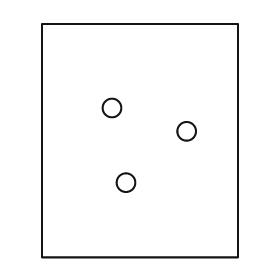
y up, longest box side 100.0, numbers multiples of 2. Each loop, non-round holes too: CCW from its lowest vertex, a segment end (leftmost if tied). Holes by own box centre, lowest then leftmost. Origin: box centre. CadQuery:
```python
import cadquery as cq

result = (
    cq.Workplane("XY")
    .moveTo(-42.0, -50.0)
    .lineTo(42.0, -50.0)
    .lineTo(42.0, 50.0)
    .lineTo(-42.0, 50.0)
    .close()
    .moveTo(-6.0, -18.0)
    .circle(4.0)
    .moveTo(20.0, 4.0)
    .circle(4.0)
    .moveTo(-12.0, 14.0)
    .circle(4.0)
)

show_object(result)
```